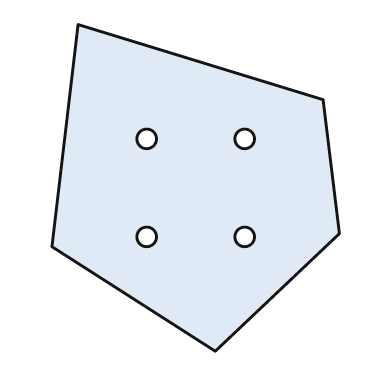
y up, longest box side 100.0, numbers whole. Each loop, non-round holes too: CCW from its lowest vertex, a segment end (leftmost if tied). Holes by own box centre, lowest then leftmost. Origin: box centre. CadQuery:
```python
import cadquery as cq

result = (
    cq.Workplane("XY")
    .moveTo(6.0, -50.0)
    .lineTo(44.0, -14.0)
    .lineTo(39.0, 27.0)
    .lineTo(-36.0, 50.0)
    .lineTo(-44.0, -18.0)
    .close()
    .moveTo(-15.0, -15.0)
    .circle(3.0)
    .moveTo(15.0, -15.0)
    .circle(3.0)
    .moveTo(-15.0, 15.0)
    .circle(3.0)
    .moveTo(15.0, 15.0)
    .circle(3.0)
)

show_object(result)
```